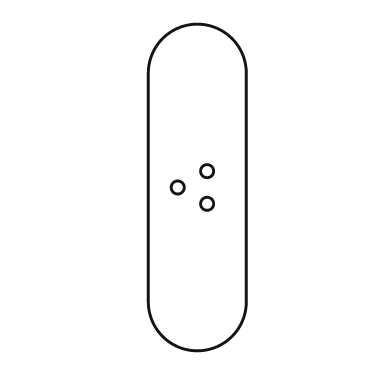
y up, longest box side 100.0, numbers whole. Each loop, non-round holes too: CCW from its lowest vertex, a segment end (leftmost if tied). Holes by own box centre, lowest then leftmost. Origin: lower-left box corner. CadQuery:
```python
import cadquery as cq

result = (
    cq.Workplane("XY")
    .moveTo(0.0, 15.0)
    .threePointArc((15.0, 0.0), (30.0, 15.0))
    .lineTo(30.0, 85.0)
    .threePointArc((15.0, 100.0), (0.0, 85.0))
    .close()
    .moveTo(18.0, 45.0)
    .circle(2.0)
    .moveTo(9.0, 50.0)
    .circle(2.0)
    .moveTo(18.0, 55.0)
    .circle(2.0)
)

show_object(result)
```